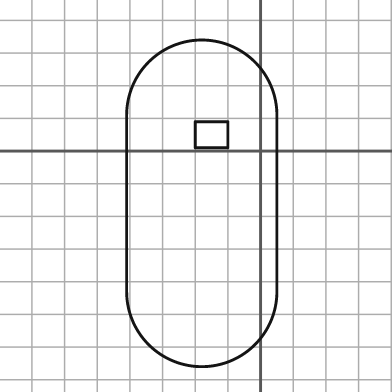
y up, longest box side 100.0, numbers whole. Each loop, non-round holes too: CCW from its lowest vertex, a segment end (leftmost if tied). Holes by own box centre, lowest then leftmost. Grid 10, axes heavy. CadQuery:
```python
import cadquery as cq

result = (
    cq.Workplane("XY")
    .moveTo(-41.0, -43.0)
    .threePointArc((-18.0, -66.0), (5.0, -43.0))
    .lineTo(5.0, 11.0)
    .threePointArc((-18.0, 34.0), (-41.0, 11.0))
    .close()
    .moveTo(-20.0, 1.0)
    .lineTo(-10.0, 1.0)
    .lineTo(-10.0, 9.0)
    .lineTo(-20.0, 9.0)
    .close()
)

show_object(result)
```